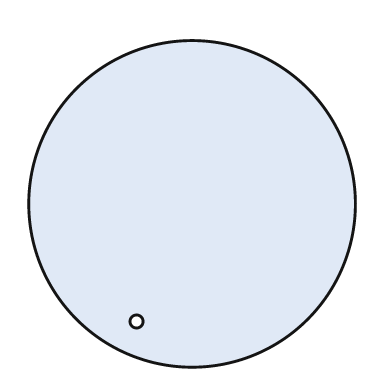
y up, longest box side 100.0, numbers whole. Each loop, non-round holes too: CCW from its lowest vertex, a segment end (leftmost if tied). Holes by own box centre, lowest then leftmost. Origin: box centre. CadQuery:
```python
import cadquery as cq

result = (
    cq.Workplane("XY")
    .moveTo(0.0, 0.0)
    .circle(50.0)
    .moveTo(-17.0, -36.0)
    .circle(2.0)
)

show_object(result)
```